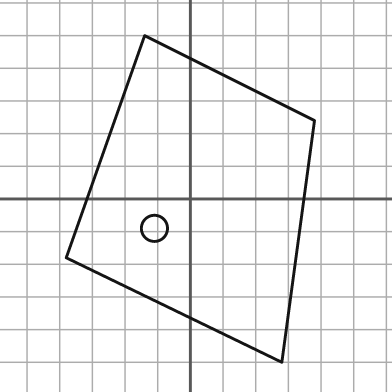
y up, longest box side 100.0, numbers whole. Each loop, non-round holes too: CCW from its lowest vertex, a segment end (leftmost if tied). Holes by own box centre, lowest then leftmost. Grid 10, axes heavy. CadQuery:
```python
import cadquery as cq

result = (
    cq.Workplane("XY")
    .moveTo(28.0, -50.0)
    .lineTo(38.0, 24.0)
    .lineTo(-14.0, 50.0)
    .lineTo(-38.0, -18.0)
    .close()
    .moveTo(-11.0, -9.0)
    .circle(4.0)
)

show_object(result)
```